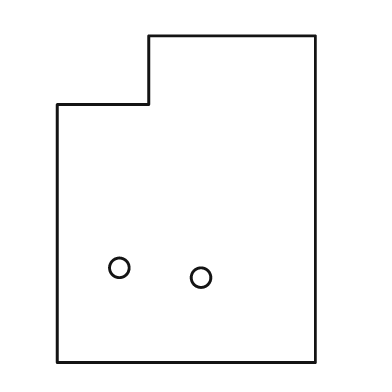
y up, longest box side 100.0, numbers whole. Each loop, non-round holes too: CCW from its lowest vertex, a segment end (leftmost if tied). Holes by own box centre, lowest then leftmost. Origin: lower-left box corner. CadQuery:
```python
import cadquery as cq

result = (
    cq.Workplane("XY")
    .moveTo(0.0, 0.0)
    .lineTo(79.0, 0.0)
    .lineTo(79.0, 100.0)
    .lineTo(28.0, 100.0)
    .lineTo(28.0, 79.0)
    .lineTo(0.0, 79.0)
    .close()
    .moveTo(44.0, 26.0)
    .circle(3.0)
    .moveTo(19.0, 29.0)
    .circle(3.0)
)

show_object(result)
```